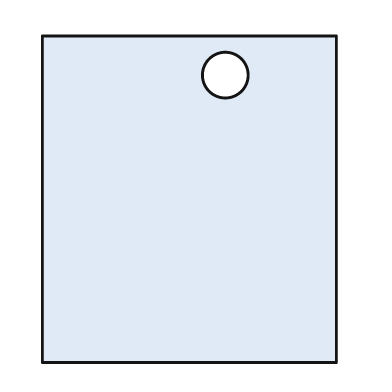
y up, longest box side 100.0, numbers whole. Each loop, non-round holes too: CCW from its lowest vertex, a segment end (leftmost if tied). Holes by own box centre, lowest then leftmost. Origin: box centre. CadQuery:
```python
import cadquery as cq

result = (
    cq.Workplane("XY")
    .moveTo(-45.0, -50.0)
    .lineTo(45.0, -50.0)
    .lineTo(45.0, 50.0)
    .lineTo(-45.0, 50.0)
    .close()
    .moveTo(11.0, 38.0)
    .circle(7.0)
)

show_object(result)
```